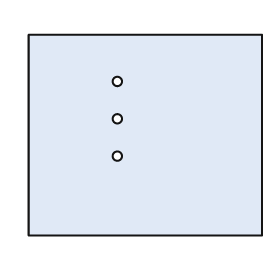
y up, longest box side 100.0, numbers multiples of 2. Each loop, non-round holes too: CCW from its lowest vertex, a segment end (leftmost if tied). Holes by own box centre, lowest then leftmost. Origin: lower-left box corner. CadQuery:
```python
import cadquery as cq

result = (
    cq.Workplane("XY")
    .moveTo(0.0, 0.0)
    .lineTo(100.0, 0.0)
    .lineTo(100.0, 86.0)
    .lineTo(0.0, 86.0)
    .close()
    .moveTo(38.0, 34.0)
    .circle(2.0)
    .moveTo(38.0, 50.0)
    .circle(2.0)
    .moveTo(38.0, 66.0)
    .circle(2.0)
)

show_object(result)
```